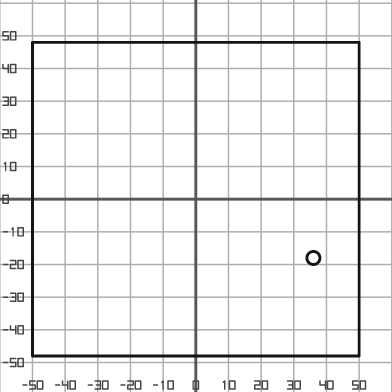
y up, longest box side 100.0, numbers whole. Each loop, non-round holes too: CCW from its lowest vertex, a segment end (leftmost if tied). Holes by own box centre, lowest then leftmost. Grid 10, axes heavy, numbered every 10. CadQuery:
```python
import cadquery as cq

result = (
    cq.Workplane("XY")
    .moveTo(-50.0, -48.0)
    .lineTo(50.0, -48.0)
    .lineTo(50.0, 48.0)
    .lineTo(-50.0, 48.0)
    .close()
    .moveTo(36.0, -18.0)
    .circle(2.0)
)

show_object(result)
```